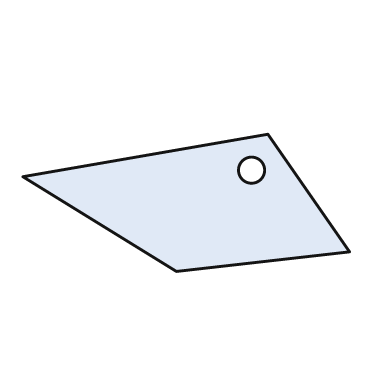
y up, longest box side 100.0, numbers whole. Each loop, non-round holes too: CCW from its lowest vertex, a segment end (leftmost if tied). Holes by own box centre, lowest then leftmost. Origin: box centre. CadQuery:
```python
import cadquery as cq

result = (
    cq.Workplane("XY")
    .moveTo(-3.0, -21.0)
    .lineTo(50.0, -15.0)
    .lineTo(25.0, 21.0)
    .lineTo(-50.0, 8.0)
    .close()
    .moveTo(20.0, 10.0)
    .circle(4.0)
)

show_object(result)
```